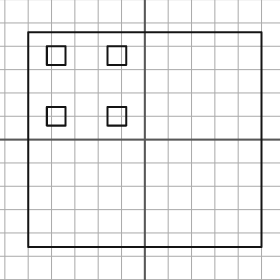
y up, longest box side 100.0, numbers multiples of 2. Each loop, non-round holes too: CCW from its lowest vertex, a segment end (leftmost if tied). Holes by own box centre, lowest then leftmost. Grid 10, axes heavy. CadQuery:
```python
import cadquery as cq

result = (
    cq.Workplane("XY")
    .moveTo(-50.0, -46.0)
    .lineTo(50.0, -46.0)
    .lineTo(50.0, 46.0)
    .lineTo(-50.0, 46.0)
    .close()
    .moveTo(-42.0, 6.0)
    .lineTo(-34.0, 6.0)
    .lineTo(-34.0, 14.0)
    .lineTo(-42.0, 14.0)
    .close()
    .moveTo(-16.0, 6.0)
    .lineTo(-8.0, 6.0)
    .lineTo(-8.0, 14.0)
    .lineTo(-16.0, 14.0)
    .close()
    .moveTo(-42.0, 32.0)
    .lineTo(-34.0, 32.0)
    .lineTo(-34.0, 40.0)
    .lineTo(-42.0, 40.0)
    .close()
    .moveTo(-16.0, 32.0)
    .lineTo(-8.0, 32.0)
    .lineTo(-8.0, 40.0)
    .lineTo(-16.0, 40.0)
    .close()
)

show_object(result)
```